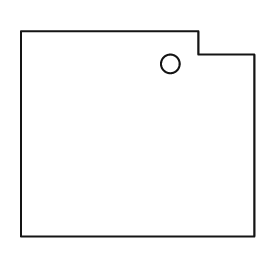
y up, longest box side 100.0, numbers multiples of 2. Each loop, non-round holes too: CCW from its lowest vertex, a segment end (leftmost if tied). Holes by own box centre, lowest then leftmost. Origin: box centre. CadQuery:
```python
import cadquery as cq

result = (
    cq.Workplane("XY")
    .moveTo(-50.0, -44.0)
    .lineTo(50.0, -44.0)
    .lineTo(50.0, 34.0)
    .lineTo(26.0, 34.0)
    .lineTo(26.0, 44.0)
    .lineTo(-50.0, 44.0)
    .close()
    .moveTo(14.0, 30.0)
    .circle(4.0)
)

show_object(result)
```